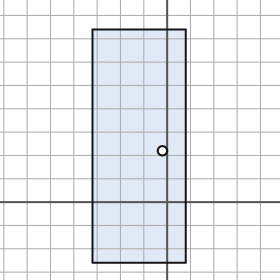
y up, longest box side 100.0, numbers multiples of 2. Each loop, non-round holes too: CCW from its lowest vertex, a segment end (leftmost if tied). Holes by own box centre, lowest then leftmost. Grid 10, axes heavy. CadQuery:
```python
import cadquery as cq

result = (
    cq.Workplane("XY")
    .moveTo(-32.0, -26.0)
    .lineTo(8.0, -26.0)
    .lineTo(8.0, 74.0)
    .lineTo(-32.0, 74.0)
    .close()
    .moveTo(-2.0, 22.0)
    .circle(2.0)
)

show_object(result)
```